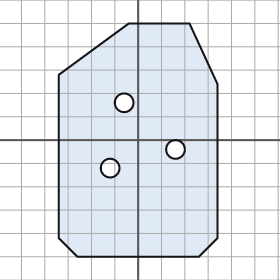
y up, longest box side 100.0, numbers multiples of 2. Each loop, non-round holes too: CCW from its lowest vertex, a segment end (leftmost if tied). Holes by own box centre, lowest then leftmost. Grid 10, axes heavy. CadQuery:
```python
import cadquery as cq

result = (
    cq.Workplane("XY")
    .moveTo(-26.0, -50.0)
    .lineTo(26.0, -50.0)
    .lineTo(34.0, -42.0)
    .lineTo(34.0, 24.0)
    .lineTo(22.0, 50.0)
    .lineTo(-4.0, 50.0)
    .lineTo(-34.0, 28.0)
    .lineTo(-34.0, -42.0)
    .close()
    .moveTo(-12.0, -12.0)
    .circle(4.0)
    .moveTo(16.0, -4.0)
    .circle(4.0)
    .moveTo(-6.0, 16.0)
    .circle(4.0)
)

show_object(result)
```